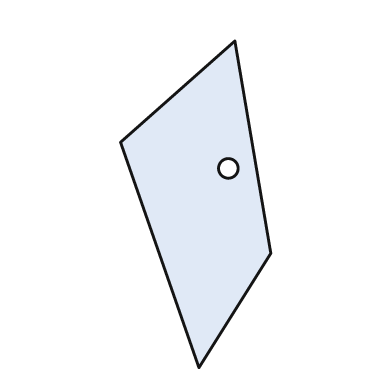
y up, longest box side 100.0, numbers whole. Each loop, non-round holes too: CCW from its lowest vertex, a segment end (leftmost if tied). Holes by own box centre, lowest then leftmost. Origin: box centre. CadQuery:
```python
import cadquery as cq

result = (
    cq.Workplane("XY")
    .moveTo(1.0, -50.0)
    .lineTo(23.0, -15.0)
    .lineTo(12.0, 50.0)
    .lineTo(-23.0, 19.0)
    .close()
    .moveTo(10.0, 11.0)
    .circle(3.0)
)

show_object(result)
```